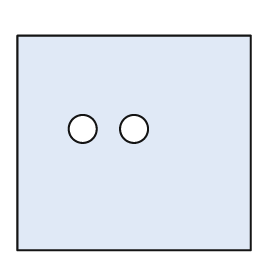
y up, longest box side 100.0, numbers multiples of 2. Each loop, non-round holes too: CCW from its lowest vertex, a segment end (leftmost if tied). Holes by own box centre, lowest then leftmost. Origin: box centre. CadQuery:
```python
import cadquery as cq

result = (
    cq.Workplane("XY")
    .moveTo(-50.0, -46.0)
    .lineTo(50.0, -46.0)
    .lineTo(50.0, 46.0)
    .lineTo(-50.0, 46.0)
    .close()
    .moveTo(-22.0, 6.0)
    .circle(6.0)
    .moveTo(0.0, 6.0)
    .circle(6.0)
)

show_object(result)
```